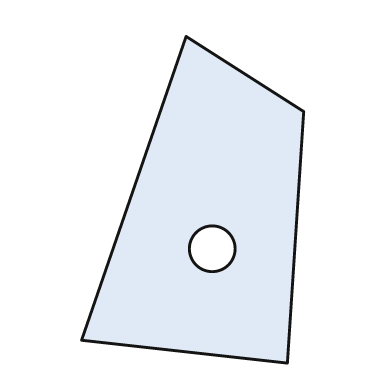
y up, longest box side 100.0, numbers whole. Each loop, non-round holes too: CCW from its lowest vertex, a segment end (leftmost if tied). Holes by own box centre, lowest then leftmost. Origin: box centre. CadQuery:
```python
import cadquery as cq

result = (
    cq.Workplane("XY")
    .moveTo(29.0, -50.0)
    .lineTo(34.0, 27.0)
    .lineTo(-2.0, 50.0)
    .lineTo(-34.0, -43.0)
    .close()
    .moveTo(6.0, -15.0)
    .circle(7.0)
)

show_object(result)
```